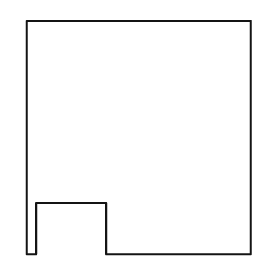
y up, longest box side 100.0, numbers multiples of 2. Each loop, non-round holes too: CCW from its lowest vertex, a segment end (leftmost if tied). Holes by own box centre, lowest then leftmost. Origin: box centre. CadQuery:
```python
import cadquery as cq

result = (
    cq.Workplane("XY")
    .moveTo(-48.0, -50.0)
    .lineTo(-44.0, -50.0)
    .lineTo(-44.0, -28.0)
    .lineTo(-14.0, -28.0)
    .lineTo(-14.0, -50.0)
    .lineTo(48.0, -50.0)
    .lineTo(48.0, 50.0)
    .lineTo(-48.0, 50.0)
    .close()
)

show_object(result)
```